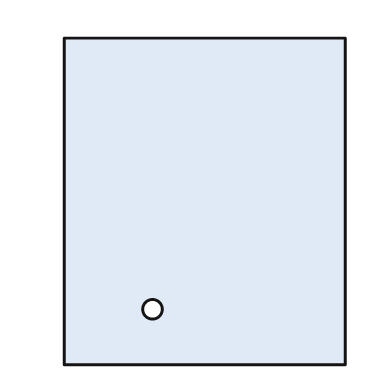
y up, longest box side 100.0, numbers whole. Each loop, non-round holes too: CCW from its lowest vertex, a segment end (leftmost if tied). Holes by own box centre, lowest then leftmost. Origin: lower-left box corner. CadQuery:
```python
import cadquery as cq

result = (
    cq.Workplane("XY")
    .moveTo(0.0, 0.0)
    .lineTo(86.0, 0.0)
    .lineTo(86.0, 100.0)
    .lineTo(0.0, 100.0)
    .close()
    .moveTo(27.0, 17.0)
    .circle(3.0)
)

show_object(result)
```